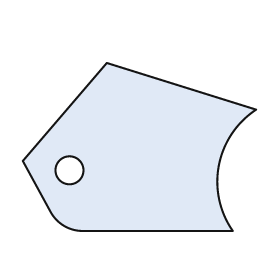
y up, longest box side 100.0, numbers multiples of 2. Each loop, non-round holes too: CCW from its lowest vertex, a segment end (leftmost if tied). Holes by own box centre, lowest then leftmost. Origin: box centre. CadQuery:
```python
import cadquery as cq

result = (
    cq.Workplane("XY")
    .moveTo(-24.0, -36.0)
    .lineTo(40.0, -36.0)
    .threePointArc((34.0, -8.0), (50.0, 16.0))
    .lineTo(-14.0, 36.0)
    .lineTo(-50.0, -6.0)
    .lineTo(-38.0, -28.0)
    .threePointArc((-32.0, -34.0), (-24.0, -36.0))
    .close()
    .moveTo(-30.0, -10.0)
    .circle(6.0)
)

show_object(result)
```